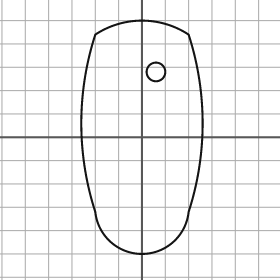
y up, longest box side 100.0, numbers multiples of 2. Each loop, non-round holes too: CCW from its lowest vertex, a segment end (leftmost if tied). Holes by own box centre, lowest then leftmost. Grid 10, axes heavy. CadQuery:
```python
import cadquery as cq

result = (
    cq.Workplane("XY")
    .moveTo(-20.0, -32.0)
    .threePointArc((0.0, -50.0), (20.0, -32.0))
    .threePointArc((26.0, 6.0), (20.0, 44.0))
    .threePointArc((0.0, 50.0), (-20.0, 44.0))
    .threePointArc((-26.0, 6.0), (-20.0, -32.0))
    .close()
    .moveTo(6.0, 28.0)
    .circle(4.0)
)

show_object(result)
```